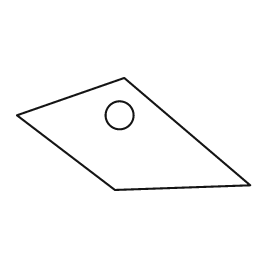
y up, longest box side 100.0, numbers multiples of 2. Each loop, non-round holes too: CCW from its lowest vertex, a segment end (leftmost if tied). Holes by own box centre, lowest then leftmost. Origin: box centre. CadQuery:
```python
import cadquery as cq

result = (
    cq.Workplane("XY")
    .moveTo(-8.0, -24.0)
    .lineTo(50.0, -22.0)
    .lineTo(-4.0, 24.0)
    .lineTo(-50.0, 8.0)
    .close()
    .moveTo(-6.0, 8.0)
    .circle(6.0)
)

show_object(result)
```